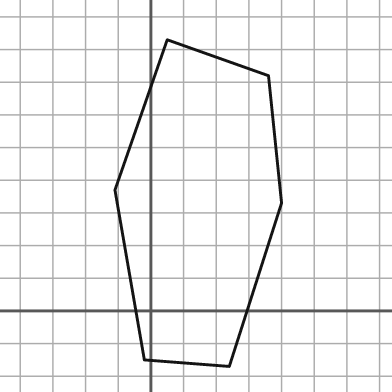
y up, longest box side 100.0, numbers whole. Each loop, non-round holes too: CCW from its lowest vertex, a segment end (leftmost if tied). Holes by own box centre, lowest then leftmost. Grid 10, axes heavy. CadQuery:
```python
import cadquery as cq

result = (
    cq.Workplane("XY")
    .moveTo(24.0, -17.0)
    .lineTo(40.0, 33.0)
    .lineTo(36.0, 72.0)
    .lineTo(5.0, 83.0)
    .lineTo(-11.0, 37.0)
    .lineTo(-2.0, -15.0)
    .close()
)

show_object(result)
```